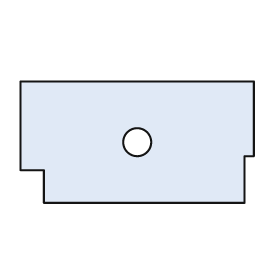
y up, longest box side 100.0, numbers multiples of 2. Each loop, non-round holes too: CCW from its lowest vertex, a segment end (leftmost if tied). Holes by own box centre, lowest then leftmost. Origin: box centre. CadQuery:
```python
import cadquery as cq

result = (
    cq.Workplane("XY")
    .moveTo(-40.0, -26.0)
    .lineTo(46.0, -26.0)
    .lineTo(46.0, -6.0)
    .lineTo(50.0, -6.0)
    .lineTo(50.0, 26.0)
    .lineTo(-50.0, 26.0)
    .lineTo(-50.0, -12.0)
    .lineTo(-40.0, -12.0)
    .close()
    .moveTo(0.0, 0.0)
    .circle(6.0)
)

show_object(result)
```